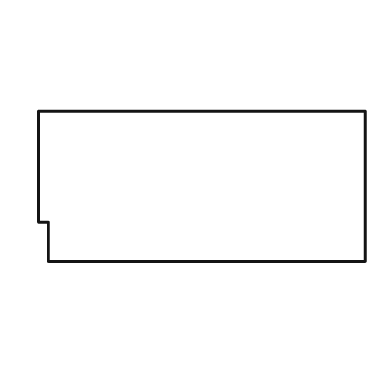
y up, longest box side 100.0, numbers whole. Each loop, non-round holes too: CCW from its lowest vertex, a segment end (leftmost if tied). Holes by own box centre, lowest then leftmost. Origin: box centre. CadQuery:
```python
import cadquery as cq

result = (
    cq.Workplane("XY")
    .moveTo(-47.0, -23.0)
    .lineTo(50.0, -23.0)
    .lineTo(50.0, 23.0)
    .lineTo(-50.0, 23.0)
    .lineTo(-50.0, -11.0)
    .lineTo(-47.0, -11.0)
    .close()
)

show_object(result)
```